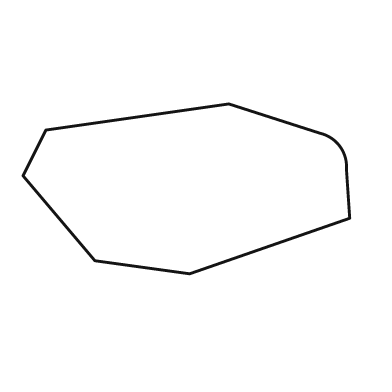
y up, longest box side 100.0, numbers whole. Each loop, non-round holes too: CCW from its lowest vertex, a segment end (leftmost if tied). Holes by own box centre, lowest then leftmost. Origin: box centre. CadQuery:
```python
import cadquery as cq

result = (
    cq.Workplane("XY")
    .moveTo(1.0, -26.0)
    .lineTo(50.0, -9.0)
    .lineTo(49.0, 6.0)
    .threePointArc((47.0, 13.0), (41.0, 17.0))
    .lineTo(13.0, 26.0)
    .lineTo(-43.0, 18.0)
    .lineTo(-50.0, 4.0)
    .lineTo(-28.0, -22.0)
    .close()
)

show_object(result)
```